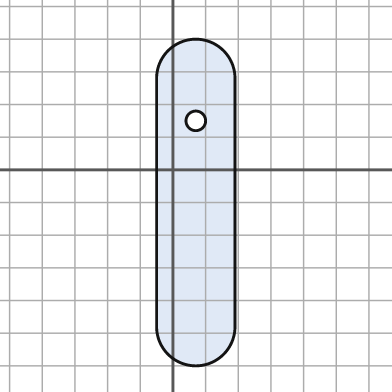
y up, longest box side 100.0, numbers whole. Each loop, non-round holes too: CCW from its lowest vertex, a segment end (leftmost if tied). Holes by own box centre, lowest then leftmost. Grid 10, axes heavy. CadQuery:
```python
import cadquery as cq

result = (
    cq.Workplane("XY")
    .moveTo(-5.0, -48.0)
    .threePointArc((7.0, -60.0), (19.0, -48.0))
    .lineTo(19.0, 28.0)
    .threePointArc((7.0, 40.0), (-5.0, 28.0))
    .close()
    .moveTo(7.0, 15.0)
    .circle(3.0)
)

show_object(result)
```